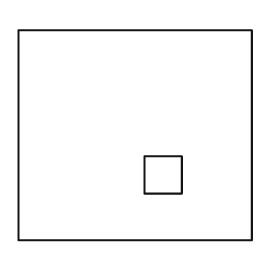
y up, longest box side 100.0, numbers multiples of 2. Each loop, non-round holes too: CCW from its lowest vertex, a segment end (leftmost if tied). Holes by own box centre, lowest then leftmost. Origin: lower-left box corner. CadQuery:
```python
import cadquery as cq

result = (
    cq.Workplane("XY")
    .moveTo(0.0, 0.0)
    .lineTo(100.0, 0.0)
    .lineTo(100.0, 90.0)
    .lineTo(0.0, 90.0)
    .close()
    .moveTo(54.0, 20.0)
    .lineTo(70.0, 20.0)
    .lineTo(70.0, 36.0)
    .lineTo(54.0, 36.0)
    .close()
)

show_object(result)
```